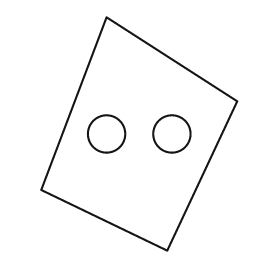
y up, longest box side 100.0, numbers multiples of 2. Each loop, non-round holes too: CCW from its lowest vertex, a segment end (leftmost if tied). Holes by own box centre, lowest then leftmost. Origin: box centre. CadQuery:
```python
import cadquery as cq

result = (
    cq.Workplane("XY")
    .moveTo(12.0, -50.0)
    .lineTo(42.0, 14.0)
    .lineTo(-14.0, 50.0)
    .lineTo(-42.0, -24.0)
    .close()
    .moveTo(-14.0, 0.0)
    .circle(8.0)
    .moveTo(14.0, 0.0)
    .circle(8.0)
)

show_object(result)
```